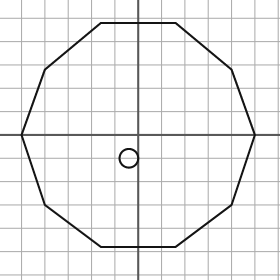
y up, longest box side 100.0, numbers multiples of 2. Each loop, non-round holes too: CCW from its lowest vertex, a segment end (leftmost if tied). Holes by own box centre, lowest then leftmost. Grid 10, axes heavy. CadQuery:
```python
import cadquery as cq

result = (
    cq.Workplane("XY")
    .moveTo(-16.0, -48.0)
    .lineTo(16.0, -48.0)
    .lineTo(40.0, -30.0)
    .lineTo(50.0, 0.0)
    .lineTo(40.0, 28.0)
    .lineTo(16.0, 48.0)
    .lineTo(-16.0, 48.0)
    .lineTo(-40.0, 28.0)
    .lineTo(-50.0, 0.0)
    .lineTo(-40.0, -30.0)
    .close()
    .moveTo(-4.0, -10.0)
    .circle(4.0)
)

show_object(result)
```